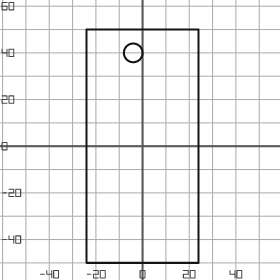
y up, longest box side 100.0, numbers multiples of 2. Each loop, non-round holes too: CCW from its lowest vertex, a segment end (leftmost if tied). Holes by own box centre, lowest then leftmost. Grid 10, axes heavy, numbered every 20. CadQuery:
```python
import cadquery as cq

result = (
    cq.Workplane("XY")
    .moveTo(-24.0, -50.0)
    .lineTo(24.0, -50.0)
    .lineTo(24.0, 50.0)
    .lineTo(-24.0, 50.0)
    .close()
    .moveTo(-4.0, 40.0)
    .circle(4.0)
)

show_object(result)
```